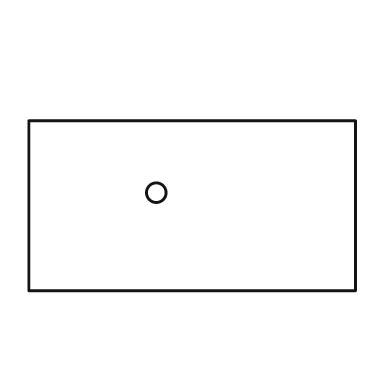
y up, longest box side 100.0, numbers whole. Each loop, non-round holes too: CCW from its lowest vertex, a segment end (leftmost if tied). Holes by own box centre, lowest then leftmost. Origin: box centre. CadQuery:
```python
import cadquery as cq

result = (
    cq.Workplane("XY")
    .moveTo(-50.0, -26.0)
    .lineTo(50.0, -26.0)
    .lineTo(50.0, 26.0)
    .lineTo(-50.0, 26.0)
    .close()
    .moveTo(-11.0, 4.0)
    .circle(3.0)
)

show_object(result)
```